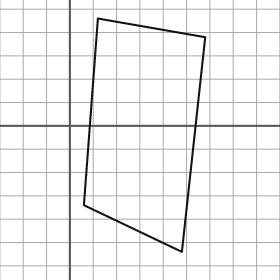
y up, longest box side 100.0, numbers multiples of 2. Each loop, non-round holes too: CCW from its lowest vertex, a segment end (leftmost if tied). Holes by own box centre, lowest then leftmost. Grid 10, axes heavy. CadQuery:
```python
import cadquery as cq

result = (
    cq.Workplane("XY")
    .moveTo(48.0, -54.0)
    .lineTo(58.0, 38.0)
    .lineTo(12.0, 46.0)
    .lineTo(6.0, -34.0)
    .close()
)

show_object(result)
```